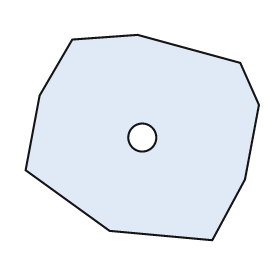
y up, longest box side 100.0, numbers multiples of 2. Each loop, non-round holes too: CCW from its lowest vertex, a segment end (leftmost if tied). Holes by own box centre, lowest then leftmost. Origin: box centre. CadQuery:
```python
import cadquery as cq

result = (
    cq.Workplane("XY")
    .moveTo(30.0, -44.0)
    .lineTo(44.0, -18.0)
    .lineTo(50.0, 14.0)
    .lineTo(42.0, 32.0)
    .lineTo(-2.0, 44.0)
    .lineTo(-30.0, 42.0)
    .lineTo(-44.0, 18.0)
    .lineTo(-50.0, -14.0)
    .lineTo(-14.0, -40.0)
    .close()
    .moveTo(0.0, 0.0)
    .circle(6.0)
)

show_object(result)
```